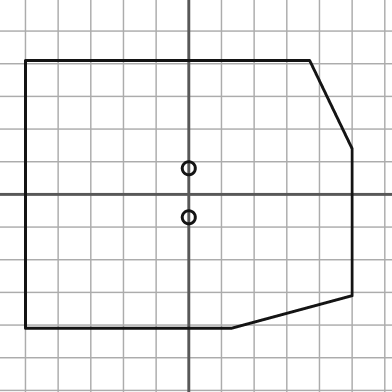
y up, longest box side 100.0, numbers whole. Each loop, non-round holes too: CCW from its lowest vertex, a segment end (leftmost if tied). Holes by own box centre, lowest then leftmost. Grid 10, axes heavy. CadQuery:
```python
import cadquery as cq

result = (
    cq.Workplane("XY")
    .moveTo(-50.0, -41.0)
    .lineTo(13.0, -41.0)
    .lineTo(50.0, -31.0)
    .lineTo(50.0, 14.0)
    .lineTo(37.0, 41.0)
    .lineTo(-50.0, 41.0)
    .close()
    .moveTo(0.0, -7.0)
    .circle(2.0)
    .moveTo(0.0, 8.0)
    .circle(2.0)
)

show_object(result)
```